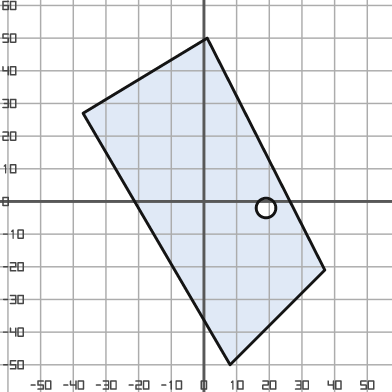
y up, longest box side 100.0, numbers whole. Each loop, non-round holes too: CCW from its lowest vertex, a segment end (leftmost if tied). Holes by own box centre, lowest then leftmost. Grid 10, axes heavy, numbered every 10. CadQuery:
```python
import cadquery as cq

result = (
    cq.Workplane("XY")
    .moveTo(8.0, -50.0)
    .lineTo(37.0, -21.0)
    .lineTo(1.0, 50.0)
    .lineTo(-37.0, 27.0)
    .close()
    .moveTo(19.0, -2.0)
    .circle(3.0)
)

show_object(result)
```